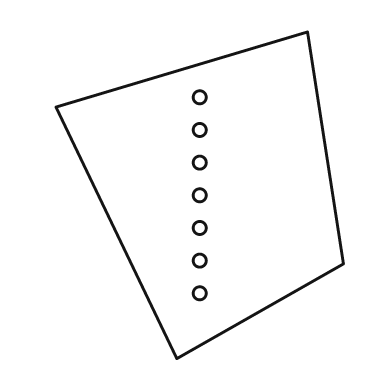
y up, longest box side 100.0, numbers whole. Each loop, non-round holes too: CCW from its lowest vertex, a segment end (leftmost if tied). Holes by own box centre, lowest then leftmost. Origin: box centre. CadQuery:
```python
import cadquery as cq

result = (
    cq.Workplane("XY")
    .moveTo(-7.0, -50.0)
    .lineTo(44.0, -21.0)
    .lineTo(33.0, 50.0)
    .lineTo(-44.0, 27.0)
    .close()
    .moveTo(0.0, -30.0)
    .circle(2.0)
    .moveTo(0.0, -20.0)
    .circle(2.0)
    .moveTo(0.0, -10.0)
    .circle(2.0)
    .moveTo(0.0, 0.0)
    .circle(2.0)
    .moveTo(0.0, 10.0)
    .circle(2.0)
    .moveTo(0.0, 20.0)
    .circle(2.0)
    .moveTo(0.0, 30.0)
    .circle(2.0)
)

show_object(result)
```